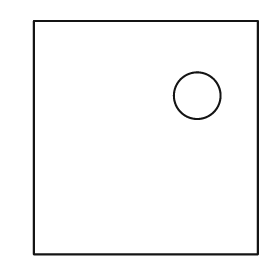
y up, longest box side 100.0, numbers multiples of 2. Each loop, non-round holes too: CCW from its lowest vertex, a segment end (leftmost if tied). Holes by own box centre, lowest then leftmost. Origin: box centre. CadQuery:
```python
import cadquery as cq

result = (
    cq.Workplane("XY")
    .moveTo(-48.0, -50.0)
    .lineTo(48.0, -50.0)
    .lineTo(48.0, 50.0)
    .lineTo(-48.0, 50.0)
    .close()
    .moveTo(22.0, 18.0)
    .circle(10.0)
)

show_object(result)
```